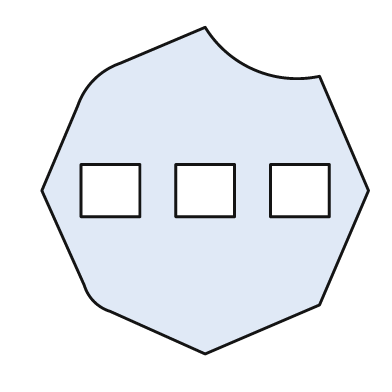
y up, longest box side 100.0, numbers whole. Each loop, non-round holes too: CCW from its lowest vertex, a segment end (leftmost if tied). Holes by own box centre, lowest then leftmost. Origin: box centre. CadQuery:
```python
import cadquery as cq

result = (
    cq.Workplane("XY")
    .moveTo(0.0, -50.0)
    .lineTo(35.0, -35.0)
    .lineTo(50.0, 0.0)
    .lineTo(35.0, 35.0)
    .threePointArc((15.0, 37.0), (0.0, 50.0))
    .lineTo(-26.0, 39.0)
    .threePointArc((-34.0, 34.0), (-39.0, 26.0))
    .lineTo(-50.0, 0.0)
    .lineTo(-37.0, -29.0)
    .threePointArc((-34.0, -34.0), (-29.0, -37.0))
    .close()
    .moveTo(-38.0, -8.0)
    .lineTo(-20.0, -8.0)
    .lineTo(-20.0, 8.0)
    .lineTo(-38.0, 8.0)
    .close()
    .moveTo(-9.0, -8.0)
    .lineTo(9.0, -8.0)
    .lineTo(9.0, 8.0)
    .lineTo(-9.0, 8.0)
    .close()
    .moveTo(20.0, -8.0)
    .lineTo(38.0, -8.0)
    .lineTo(38.0, 8.0)
    .lineTo(20.0, 8.0)
    .close()
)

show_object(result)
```